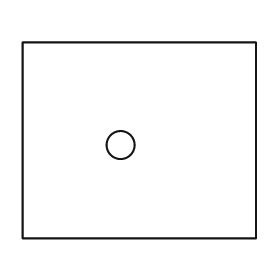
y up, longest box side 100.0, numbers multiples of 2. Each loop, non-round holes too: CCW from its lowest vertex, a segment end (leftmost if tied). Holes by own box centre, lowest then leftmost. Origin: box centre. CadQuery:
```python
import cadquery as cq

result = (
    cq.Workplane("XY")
    .moveTo(-50.0, -42.0)
    .lineTo(50.0, -42.0)
    .lineTo(50.0, 42.0)
    .lineTo(-50.0, 42.0)
    .close()
    .moveTo(-8.0, -2.0)
    .circle(6.0)
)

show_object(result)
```